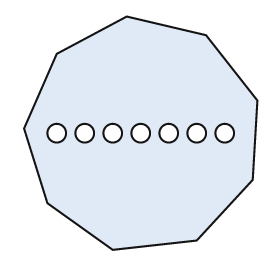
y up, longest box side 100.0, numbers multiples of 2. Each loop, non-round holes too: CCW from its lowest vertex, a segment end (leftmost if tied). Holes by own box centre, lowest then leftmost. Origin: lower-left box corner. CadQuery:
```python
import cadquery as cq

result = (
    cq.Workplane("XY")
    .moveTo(38.0, 0.0)
    .lineTo(74.0, 4.0)
    .lineTo(98.0, 30.0)
    .lineTo(100.0, 64.0)
    .lineTo(78.0, 92.0)
    .lineTo(44.0, 100.0)
    .lineTo(14.0, 84.0)
    .lineTo(0.0, 52.0)
    .lineTo(10.0, 20.0)
    .close()
    .moveTo(14.0, 50.0)
    .circle(4.0)
    .moveTo(26.0, 50.0)
    .circle(4.0)
    .moveTo(38.0, 50.0)
    .circle(4.0)
    .moveTo(50.0, 50.0)
    .circle(4.0)
    .moveTo(62.0, 50.0)
    .circle(4.0)
    .moveTo(74.0, 50.0)
    .circle(4.0)
    .moveTo(86.0, 50.0)
    .circle(4.0)
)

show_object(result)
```